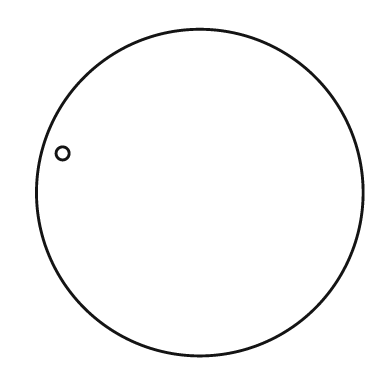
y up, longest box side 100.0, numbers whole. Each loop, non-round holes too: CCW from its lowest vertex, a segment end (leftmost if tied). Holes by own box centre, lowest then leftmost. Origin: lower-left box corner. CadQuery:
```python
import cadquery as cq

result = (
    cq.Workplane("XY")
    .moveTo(50.0, 50.0)
    .circle(50.0)
    .moveTo(8.0, 62.0)
    .circle(2.0)
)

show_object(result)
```